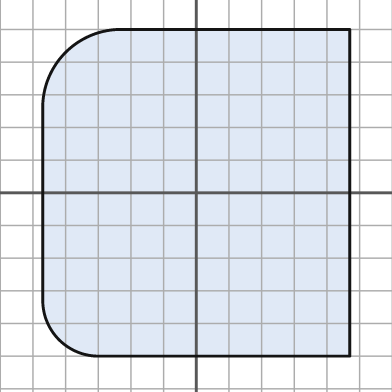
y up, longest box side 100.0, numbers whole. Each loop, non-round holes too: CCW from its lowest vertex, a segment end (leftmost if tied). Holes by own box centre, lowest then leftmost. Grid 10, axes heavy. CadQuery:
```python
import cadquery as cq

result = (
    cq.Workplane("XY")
    .moveTo(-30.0, -50.0)
    .lineTo(47.0, -50.0)
    .lineTo(47.0, 50.0)
    .lineTo(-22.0, 50.0)
    .threePointArc((-40.0, 43.0), (-47.0, 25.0))
    .lineTo(-47.0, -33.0)
    .threePointArc((-42.0, -45.0), (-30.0, -50.0))
    .close()
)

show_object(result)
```